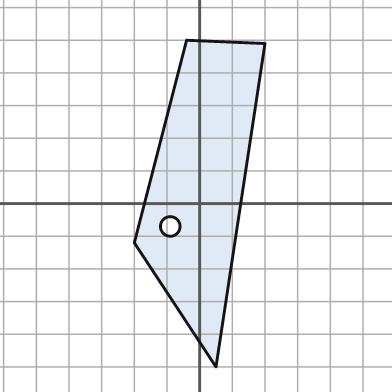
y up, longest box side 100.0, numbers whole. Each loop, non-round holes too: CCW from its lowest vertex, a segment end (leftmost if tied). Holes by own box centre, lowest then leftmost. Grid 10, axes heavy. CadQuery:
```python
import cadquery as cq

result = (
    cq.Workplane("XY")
    .moveTo(5.0, -50.0)
    .lineTo(20.0, 49.0)
    .lineTo(-4.0, 50.0)
    .lineTo(-20.0, -12.0)
    .close()
    .moveTo(-9.0, -7.0)
    .circle(3.0)
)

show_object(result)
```